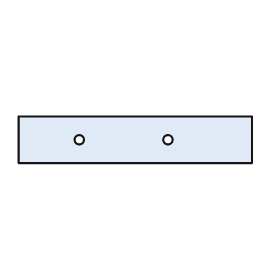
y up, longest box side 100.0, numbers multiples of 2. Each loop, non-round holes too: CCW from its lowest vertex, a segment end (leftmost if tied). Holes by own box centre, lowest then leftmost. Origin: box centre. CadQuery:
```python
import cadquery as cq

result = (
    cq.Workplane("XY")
    .moveTo(-50.0, -10.0)
    .lineTo(50.0, -10.0)
    .lineTo(50.0, 10.0)
    .lineTo(-50.0, 10.0)
    .close()
    .moveTo(-24.0, 0.0)
    .circle(2.0)
    .moveTo(14.0, 0.0)
    .circle(2.0)
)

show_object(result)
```